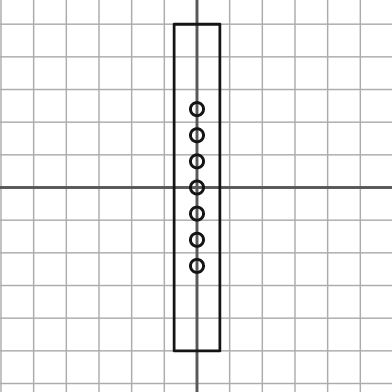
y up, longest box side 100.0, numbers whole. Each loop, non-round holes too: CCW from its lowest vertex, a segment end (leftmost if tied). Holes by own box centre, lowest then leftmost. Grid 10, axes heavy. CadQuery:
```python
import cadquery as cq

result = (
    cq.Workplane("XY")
    .moveTo(-7.0, -50.0)
    .lineTo(7.0, -50.0)
    .lineTo(7.0, 50.0)
    .lineTo(-7.0, 50.0)
    .close()
    .moveTo(0.0, -24.0)
    .circle(2.0)
    .moveTo(0.0, -16.0)
    .circle(2.0)
    .moveTo(0.0, -8.0)
    .circle(2.0)
    .moveTo(0.0, 0.0)
    .circle(2.0)
    .moveTo(0.0, 8.0)
    .circle(2.0)
    .moveTo(0.0, 16.0)
    .circle(2.0)
    .moveTo(0.0, 24.0)
    .circle(2.0)
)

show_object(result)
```